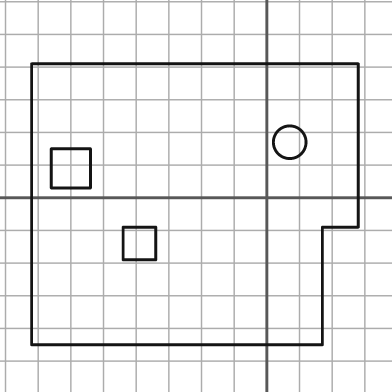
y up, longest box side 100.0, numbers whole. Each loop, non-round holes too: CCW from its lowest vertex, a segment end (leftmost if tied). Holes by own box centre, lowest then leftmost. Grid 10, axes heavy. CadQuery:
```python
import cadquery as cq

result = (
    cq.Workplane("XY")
    .moveTo(-72.0, -45.0)
    .lineTo(17.0, -45.0)
    .lineTo(17.0, -9.0)
    .lineTo(28.0, -9.0)
    .lineTo(28.0, 41.0)
    .lineTo(-72.0, 41.0)
    .close()
    .moveTo(-44.0, -19.0)
    .lineTo(-34.0, -19.0)
    .lineTo(-34.0, -9.0)
    .lineTo(-44.0, -9.0)
    .close()
    .moveTo(-66.0, 3.0)
    .lineTo(-54.0, 3.0)
    .lineTo(-54.0, 15.0)
    .lineTo(-66.0, 15.0)
    .close()
    .moveTo(7.0, 17.0)
    .circle(5.0)
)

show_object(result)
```